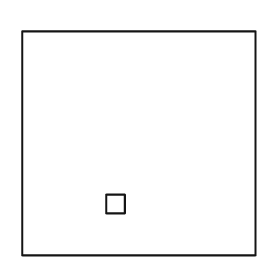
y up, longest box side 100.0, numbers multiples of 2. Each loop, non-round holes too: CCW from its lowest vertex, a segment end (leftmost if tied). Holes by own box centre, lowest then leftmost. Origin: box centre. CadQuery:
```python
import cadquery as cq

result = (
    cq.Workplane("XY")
    .moveTo(-50.0, -48.0)
    .lineTo(50.0, -48.0)
    .lineTo(50.0, 48.0)
    .lineTo(-50.0, 48.0)
    .close()
    .moveTo(-14.0, -30.0)
    .lineTo(-6.0, -30.0)
    .lineTo(-6.0, -22.0)
    .lineTo(-14.0, -22.0)
    .close()
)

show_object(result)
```